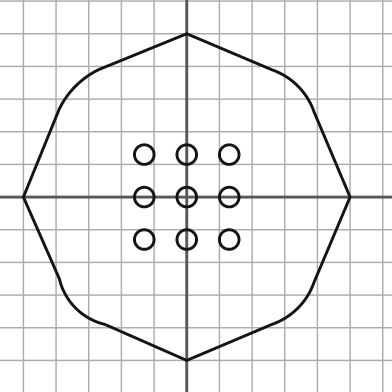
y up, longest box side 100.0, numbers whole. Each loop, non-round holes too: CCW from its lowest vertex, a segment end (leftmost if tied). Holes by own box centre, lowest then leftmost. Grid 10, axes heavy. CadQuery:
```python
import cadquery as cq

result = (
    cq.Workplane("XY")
    .moveTo(0.0, -50.0)
    .lineTo(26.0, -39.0)
    .threePointArc((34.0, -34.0), (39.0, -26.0))
    .lineTo(50.0, 0.0)
    .lineTo(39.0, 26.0)
    .threePointArc((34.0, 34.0), (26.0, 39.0))
    .lineTo(0.0, 50.0)
    .lineTo(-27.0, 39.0)
    .threePointArc((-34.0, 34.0), (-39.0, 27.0))
    .lineTo(-50.0, 0.0)
    .lineTo(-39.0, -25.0)
    .threePointArc((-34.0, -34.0), (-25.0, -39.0))
    .close()
    .moveTo(-13.0, -13.0)
    .circle(3.0)
    .moveTo(0.0, -13.0)
    .circle(3.0)
    .moveTo(13.0, -13.0)
    .circle(3.0)
    .moveTo(-13.0, 0.0)
    .circle(3.0)
    .moveTo(0.0, 0.0)
    .circle(3.0)
    .moveTo(13.0, 0.0)
    .circle(3.0)
    .moveTo(-13.0, 13.0)
    .circle(3.0)
    .moveTo(0.0, 13.0)
    .circle(3.0)
    .moveTo(13.0, 13.0)
    .circle(3.0)
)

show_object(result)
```